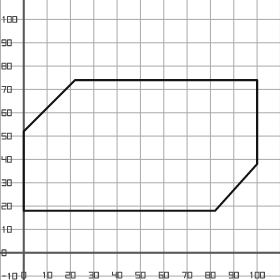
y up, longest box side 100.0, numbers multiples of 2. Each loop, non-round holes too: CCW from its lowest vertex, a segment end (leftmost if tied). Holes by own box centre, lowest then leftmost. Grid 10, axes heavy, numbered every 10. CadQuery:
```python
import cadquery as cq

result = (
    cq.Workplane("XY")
    .moveTo(0.0, 18.0)
    .lineTo(82.0, 18.0)
    .lineTo(100.0, 38.0)
    .lineTo(100.0, 74.0)
    .lineTo(22.0, 74.0)
    .lineTo(0.0, 52.0)
    .close()
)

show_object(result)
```